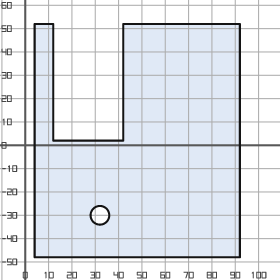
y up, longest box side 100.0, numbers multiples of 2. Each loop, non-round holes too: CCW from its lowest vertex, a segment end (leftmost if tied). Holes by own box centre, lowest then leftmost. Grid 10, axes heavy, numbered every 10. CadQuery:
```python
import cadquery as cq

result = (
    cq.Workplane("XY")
    .moveTo(4.0, -48.0)
    .lineTo(92.0, -48.0)
    .lineTo(92.0, 52.0)
    .lineTo(42.0, 52.0)
    .lineTo(42.0, 2.0)
    .lineTo(12.0, 2.0)
    .lineTo(12.0, 52.0)
    .lineTo(4.0, 52.0)
    .close()
    .moveTo(32.0, -30.0)
    .circle(4.0)
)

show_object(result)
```